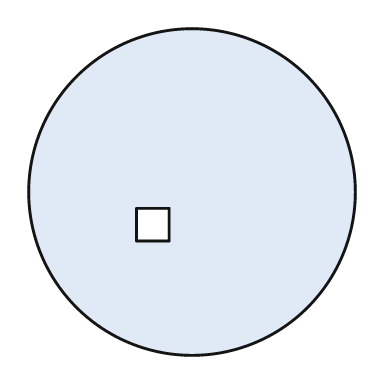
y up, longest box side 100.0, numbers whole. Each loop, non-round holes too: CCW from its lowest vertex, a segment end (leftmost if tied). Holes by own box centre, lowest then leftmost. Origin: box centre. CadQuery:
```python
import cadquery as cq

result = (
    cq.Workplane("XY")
    .moveTo(0.0, 0.0)
    .circle(50.0)
    .moveTo(-17.0, -15.0)
    .lineTo(-7.0, -15.0)
    .lineTo(-7.0, -5.0)
    .lineTo(-17.0, -5.0)
    .close()
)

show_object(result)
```